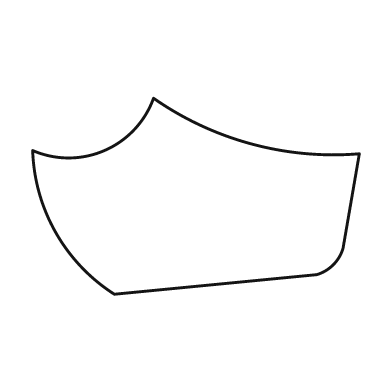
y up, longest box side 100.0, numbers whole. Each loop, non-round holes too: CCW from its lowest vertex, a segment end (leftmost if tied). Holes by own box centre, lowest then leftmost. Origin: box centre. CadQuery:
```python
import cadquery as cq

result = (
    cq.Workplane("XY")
    .moveTo(-25.0, -30.0)
    .lineTo(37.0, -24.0)
    .threePointArc((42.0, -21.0), (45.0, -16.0))
    .lineTo(50.0, 13.0)
    .threePointArc((17.0, 16.0), (-13.0, 30.0))
    .threePointArc((-28.0, 14.0), (-50.0, 14.0))
    .threePointArc((-43.0, -11.0), (-25.0, -30.0))
    .close()
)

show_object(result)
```